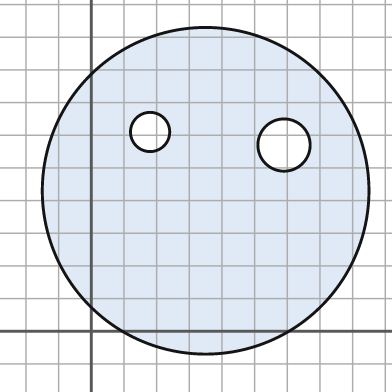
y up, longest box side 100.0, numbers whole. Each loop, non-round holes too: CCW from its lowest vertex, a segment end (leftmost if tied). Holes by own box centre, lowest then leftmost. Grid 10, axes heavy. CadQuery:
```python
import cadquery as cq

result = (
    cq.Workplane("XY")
    .moveTo(35.0, 43.0)
    .circle(50.0)
    .moveTo(59.0, 57.0)
    .circle(8.0)
    .moveTo(18.0, 61.0)
    .circle(6.0)
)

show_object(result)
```